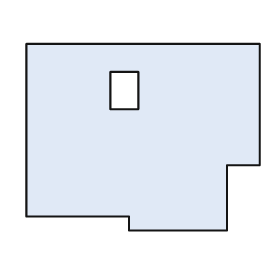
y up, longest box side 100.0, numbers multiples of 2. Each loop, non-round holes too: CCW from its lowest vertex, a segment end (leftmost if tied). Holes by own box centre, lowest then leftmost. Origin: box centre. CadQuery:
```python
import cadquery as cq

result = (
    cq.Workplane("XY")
    .moveTo(-6.0, -40.0)
    .lineTo(36.0, -40.0)
    .lineTo(36.0, -12.0)
    .lineTo(50.0, -12.0)
    .lineTo(50.0, 40.0)
    .lineTo(-50.0, 40.0)
    .lineTo(-50.0, -34.0)
    .lineTo(-6.0, -34.0)
    .close()
    .moveTo(-14.0, 12.0)
    .lineTo(-2.0, 12.0)
    .lineTo(-2.0, 28.0)
    .lineTo(-14.0, 28.0)
    .close()
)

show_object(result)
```